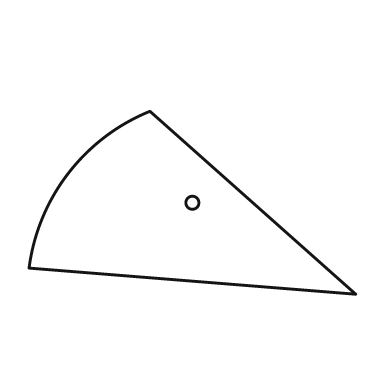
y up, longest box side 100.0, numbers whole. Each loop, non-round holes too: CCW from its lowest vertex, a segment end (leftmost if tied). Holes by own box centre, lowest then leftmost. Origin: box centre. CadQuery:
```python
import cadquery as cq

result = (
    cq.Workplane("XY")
    .moveTo(50.0, -28.0)
    .lineTo(-13.0, 28.0)
    .threePointArc((-38.0, 9.0), (-50.0, -20.0))
    .close()
    .moveTo(0.0, 0.0)
    .circle(2.0)
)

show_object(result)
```